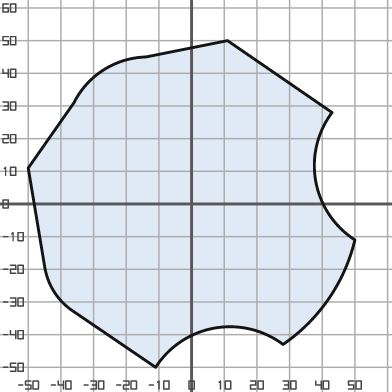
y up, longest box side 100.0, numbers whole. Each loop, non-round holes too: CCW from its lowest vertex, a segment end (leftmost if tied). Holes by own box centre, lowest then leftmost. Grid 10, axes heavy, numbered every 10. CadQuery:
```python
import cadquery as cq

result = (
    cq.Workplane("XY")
    .moveTo(-11.0, -50.0)
    .threePointArc((7.0, -38.0), (28.0, -43.0))
    .threePointArc((42.0, -29.0), (50.0, -11.0))
    .threePointArc((38.0, 7.0), (43.0, 28.0))
    .lineTo(11.0, 50.0)
    .lineTo(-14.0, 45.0)
    .threePointArc((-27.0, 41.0), (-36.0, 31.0))
    .lineTo(-50.0, 11.0)
    .lineTo(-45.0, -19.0)
    .threePointArc((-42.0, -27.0), (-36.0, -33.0))
    .close()
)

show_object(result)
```